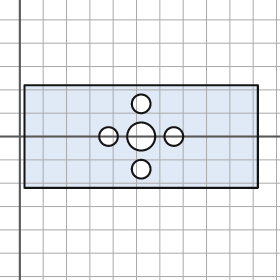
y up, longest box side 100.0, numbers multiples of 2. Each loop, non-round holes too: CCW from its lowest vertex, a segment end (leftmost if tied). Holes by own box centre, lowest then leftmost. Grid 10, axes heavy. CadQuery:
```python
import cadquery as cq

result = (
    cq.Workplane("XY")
    .moveTo(2.0, -22.0)
    .lineTo(102.0, -22.0)
    .lineTo(102.0, 22.0)
    .lineTo(2.0, 22.0)
    .close()
    .moveTo(52.0, -14.0)
    .circle(4.0)
    .moveTo(38.0, 0.0)
    .circle(4.0)
    .moveTo(52.0, 0.0)
    .circle(6.0)
    .moveTo(66.0, 0.0)
    .circle(4.0)
    .moveTo(52.0, 14.0)
    .circle(4.0)
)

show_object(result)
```